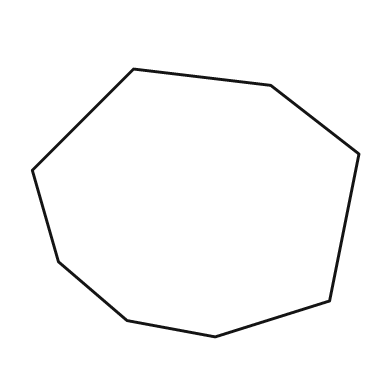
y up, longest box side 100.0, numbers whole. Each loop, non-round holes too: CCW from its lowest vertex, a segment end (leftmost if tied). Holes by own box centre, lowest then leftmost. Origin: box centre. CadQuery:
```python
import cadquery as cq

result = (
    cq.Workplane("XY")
    .moveTo(6.0, -41.0)
    .lineTo(41.0, -30.0)
    .lineTo(50.0, 15.0)
    .lineTo(23.0, 36.0)
    .lineTo(-19.0, 41.0)
    .lineTo(-50.0, 10.0)
    .lineTo(-42.0, -18.0)
    .lineTo(-21.0, -36.0)
    .close()
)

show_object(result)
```